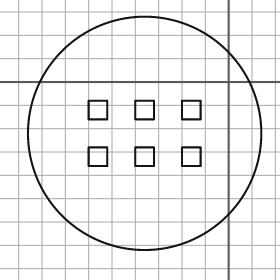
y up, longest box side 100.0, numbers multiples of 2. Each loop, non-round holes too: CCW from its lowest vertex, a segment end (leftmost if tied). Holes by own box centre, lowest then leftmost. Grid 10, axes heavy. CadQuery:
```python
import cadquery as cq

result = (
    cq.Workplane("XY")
    .moveTo(-36.0, -22.0)
    .circle(50.0)
    .moveTo(-60.0, -36.0)
    .lineTo(-52.0, -36.0)
    .lineTo(-52.0, -28.0)
    .lineTo(-60.0, -28.0)
    .close()
    .moveTo(-40.0, -36.0)
    .lineTo(-32.0, -36.0)
    .lineTo(-32.0, -28.0)
    .lineTo(-40.0, -28.0)
    .close()
    .moveTo(-20.0, -36.0)
    .lineTo(-12.0, -36.0)
    .lineTo(-12.0, -28.0)
    .lineTo(-20.0, -28.0)
    .close()
    .moveTo(-60.0, -16.0)
    .lineTo(-52.0, -16.0)
    .lineTo(-52.0, -8.0)
    .lineTo(-60.0, -8.0)
    .close()
    .moveTo(-40.0, -16.0)
    .lineTo(-32.0, -16.0)
    .lineTo(-32.0, -8.0)
    .lineTo(-40.0, -8.0)
    .close()
    .moveTo(-20.0, -16.0)
    .lineTo(-12.0, -16.0)
    .lineTo(-12.0, -8.0)
    .lineTo(-20.0, -8.0)
    .close()
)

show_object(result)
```